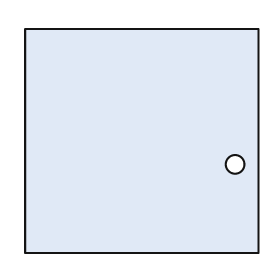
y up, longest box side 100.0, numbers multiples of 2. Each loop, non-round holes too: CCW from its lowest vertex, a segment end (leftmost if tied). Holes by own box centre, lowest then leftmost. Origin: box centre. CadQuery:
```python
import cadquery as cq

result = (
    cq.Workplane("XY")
    .moveTo(-50.0, -48.0)
    .lineTo(50.0, -48.0)
    .lineTo(50.0, 48.0)
    .lineTo(-50.0, 48.0)
    .close()
    .moveTo(40.0, -10.0)
    .circle(4.0)
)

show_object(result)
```